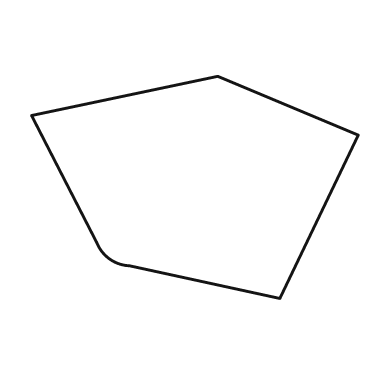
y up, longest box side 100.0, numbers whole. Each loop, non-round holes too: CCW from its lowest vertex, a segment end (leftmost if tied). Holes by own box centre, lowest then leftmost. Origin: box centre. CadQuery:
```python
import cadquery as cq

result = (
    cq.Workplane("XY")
    .moveTo(26.0, -34.0)
    .lineTo(50.0, 16.0)
    .lineTo(7.0, 34.0)
    .lineTo(-50.0, 22.0)
    .lineTo(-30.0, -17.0)
    .threePointArc((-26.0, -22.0), (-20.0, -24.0))
    .close()
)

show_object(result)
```